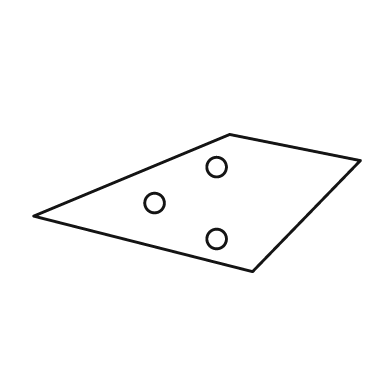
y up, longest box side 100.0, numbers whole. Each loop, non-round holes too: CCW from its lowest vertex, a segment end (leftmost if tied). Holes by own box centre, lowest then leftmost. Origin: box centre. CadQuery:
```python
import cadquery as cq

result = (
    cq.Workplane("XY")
    .moveTo(17.0, -21.0)
    .lineTo(50.0, 13.0)
    .lineTo(10.0, 21.0)
    .lineTo(-50.0, -4.0)
    .close()
    .moveTo(6.0, -11.0)
    .circle(3.0)
    .moveTo(-13.0, 0.0)
    .circle(3.0)
    .moveTo(6.0, 11.0)
    .circle(3.0)
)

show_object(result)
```